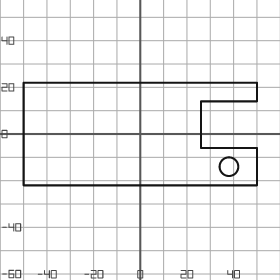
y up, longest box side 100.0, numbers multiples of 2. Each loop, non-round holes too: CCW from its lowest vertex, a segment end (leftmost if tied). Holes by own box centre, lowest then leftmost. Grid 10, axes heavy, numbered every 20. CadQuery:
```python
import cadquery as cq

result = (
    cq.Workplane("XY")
    .moveTo(-50.0, -22.0)
    .lineTo(50.0, -22.0)
    .lineTo(50.0, -6.0)
    .lineTo(26.0, -6.0)
    .lineTo(26.0, 14.0)
    .lineTo(50.0, 14.0)
    .lineTo(50.0, 22.0)
    .lineTo(-50.0, 22.0)
    .close()
    .moveTo(38.0, -14.0)
    .circle(4.0)
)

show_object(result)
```